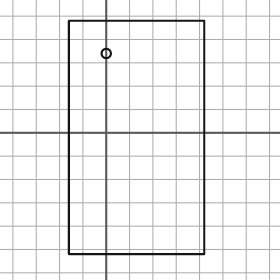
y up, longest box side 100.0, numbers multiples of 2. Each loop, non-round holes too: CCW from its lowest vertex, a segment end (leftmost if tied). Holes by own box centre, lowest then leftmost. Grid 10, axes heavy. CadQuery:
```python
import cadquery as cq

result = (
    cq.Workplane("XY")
    .moveTo(-16.0, -52.0)
    .lineTo(42.0, -52.0)
    .lineTo(42.0, 48.0)
    .lineTo(-16.0, 48.0)
    .close()
    .moveTo(0.0, 34.0)
    .circle(2.0)
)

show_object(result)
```